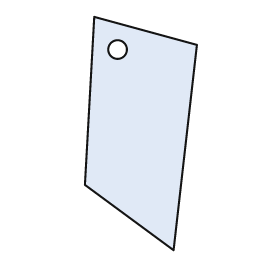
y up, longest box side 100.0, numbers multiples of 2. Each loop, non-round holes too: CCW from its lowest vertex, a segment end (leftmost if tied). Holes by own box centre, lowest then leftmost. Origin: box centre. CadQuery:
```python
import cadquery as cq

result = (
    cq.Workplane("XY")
    .moveTo(14.0, -50.0)
    .lineTo(24.0, 38.0)
    .lineTo(-20.0, 50.0)
    .lineTo(-24.0, -22.0)
    .close()
    .moveTo(-10.0, 36.0)
    .circle(4.0)
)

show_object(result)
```